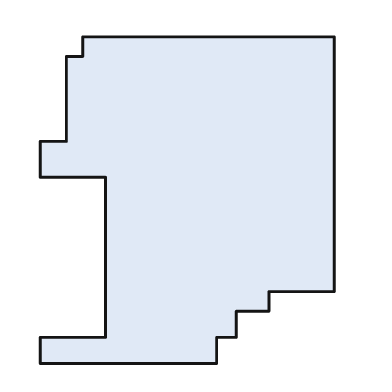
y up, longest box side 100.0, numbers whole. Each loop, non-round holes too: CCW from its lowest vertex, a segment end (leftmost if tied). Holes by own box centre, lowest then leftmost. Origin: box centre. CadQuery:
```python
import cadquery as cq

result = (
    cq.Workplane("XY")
    .moveTo(-45.0, -50.0)
    .lineTo(9.0, -50.0)
    .lineTo(9.0, -42.0)
    .lineTo(15.0, -42.0)
    .lineTo(15.0, -34.0)
    .lineTo(25.0, -34.0)
    .lineTo(25.0, -28.0)
    .lineTo(45.0, -28.0)
    .lineTo(45.0, 50.0)
    .lineTo(-32.0, 50.0)
    .lineTo(-32.0, 44.0)
    .lineTo(-37.0, 44.0)
    .lineTo(-37.0, 18.0)
    .lineTo(-45.0, 18.0)
    .lineTo(-45.0, 7.0)
    .lineTo(-25.0, 7.0)
    .lineTo(-25.0, -42.0)
    .lineTo(-45.0, -42.0)
    .close()
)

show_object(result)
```